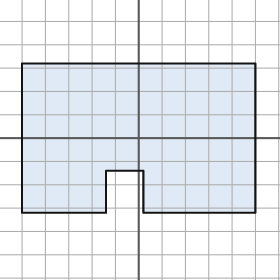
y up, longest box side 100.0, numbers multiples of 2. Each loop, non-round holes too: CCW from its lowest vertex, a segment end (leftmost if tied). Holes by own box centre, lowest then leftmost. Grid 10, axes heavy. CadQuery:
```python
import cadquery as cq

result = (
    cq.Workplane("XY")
    .moveTo(-50.0, -32.0)
    .lineTo(-14.0, -32.0)
    .lineTo(-14.0, -14.0)
    .lineTo(2.0, -14.0)
    .lineTo(2.0, -32.0)
    .lineTo(50.0, -32.0)
    .lineTo(50.0, 32.0)
    .lineTo(-50.0, 32.0)
    .close()
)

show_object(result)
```